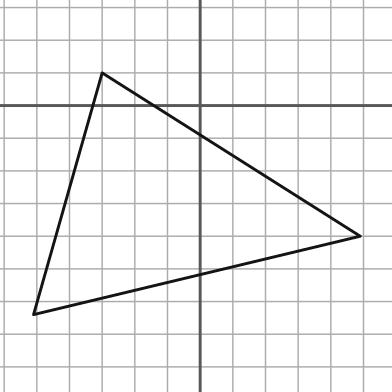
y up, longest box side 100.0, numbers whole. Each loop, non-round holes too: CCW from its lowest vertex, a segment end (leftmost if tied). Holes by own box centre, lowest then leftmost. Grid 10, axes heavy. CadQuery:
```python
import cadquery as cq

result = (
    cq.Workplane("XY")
    .moveTo(-51.0, -64.0)
    .lineTo(49.0, -40.0)
    .lineTo(-30.0, 10.0)
    .close()
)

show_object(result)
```